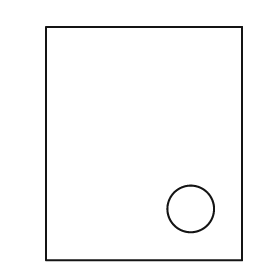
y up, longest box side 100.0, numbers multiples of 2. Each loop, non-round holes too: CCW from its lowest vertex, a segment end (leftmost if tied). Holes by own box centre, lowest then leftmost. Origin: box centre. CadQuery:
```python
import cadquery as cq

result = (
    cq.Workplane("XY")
    .moveTo(-42.0, -50.0)
    .lineTo(42.0, -50.0)
    .lineTo(42.0, 50.0)
    .lineTo(-42.0, 50.0)
    .close()
    .moveTo(20.0, -28.0)
    .circle(10.0)
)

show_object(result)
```